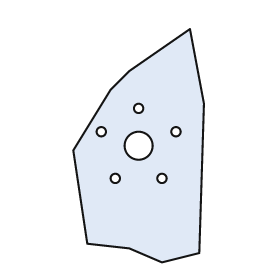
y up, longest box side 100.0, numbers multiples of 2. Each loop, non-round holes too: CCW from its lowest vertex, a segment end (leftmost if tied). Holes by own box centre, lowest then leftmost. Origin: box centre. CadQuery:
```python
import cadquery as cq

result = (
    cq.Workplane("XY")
    .moveTo(10.0, -50.0)
    .lineTo(26.0, -46.0)
    .lineTo(28.0, 18.0)
    .lineTo(22.0, 50.0)
    .lineTo(-4.0, 32.0)
    .lineTo(-12.0, 24.0)
    .lineTo(-28.0, -2.0)
    .lineTo(-22.0, -42.0)
    .lineTo(-4.0, -44.0)
    .close()
    .moveTo(-10.0, -14.0)
    .circle(2.0)
    .moveTo(10.0, -14.0)
    .circle(2.0)
    .moveTo(0.0, 0.0)
    .circle(6.0)
    .moveTo(-16.0, 6.0)
    .circle(2.0)
    .moveTo(16.0, 6.0)
    .circle(2.0)
    .moveTo(0.0, 16.0)
    .circle(2.0)
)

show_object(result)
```